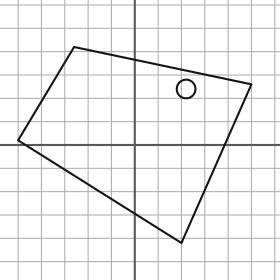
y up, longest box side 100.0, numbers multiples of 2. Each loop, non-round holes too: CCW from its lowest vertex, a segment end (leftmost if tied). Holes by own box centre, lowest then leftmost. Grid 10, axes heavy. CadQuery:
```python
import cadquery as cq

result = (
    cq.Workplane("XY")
    .moveTo(20.0, -42.0)
    .lineTo(50.0, 26.0)
    .lineTo(-26.0, 42.0)
    .lineTo(-50.0, 2.0)
    .close()
    .moveTo(22.0, 24.0)
    .circle(4.0)
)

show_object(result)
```